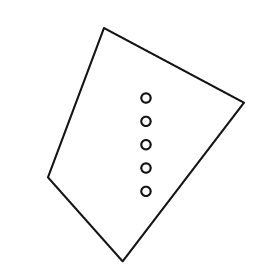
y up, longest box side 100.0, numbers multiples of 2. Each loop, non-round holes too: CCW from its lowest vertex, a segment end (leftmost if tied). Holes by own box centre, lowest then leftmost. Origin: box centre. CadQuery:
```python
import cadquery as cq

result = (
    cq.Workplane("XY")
    .moveTo(-10.0, -50.0)
    .lineTo(42.0, 18.0)
    .lineTo(-18.0, 50.0)
    .lineTo(-42.0, -14.0)
    .close()
    .moveTo(0.0, -20.0)
    .circle(2.0)
    .moveTo(0.0, -10.0)
    .circle(2.0)
    .moveTo(0.0, 0.0)
    .circle(2.0)
    .moveTo(0.0, 10.0)
    .circle(2.0)
    .moveTo(0.0, 20.0)
    .circle(2.0)
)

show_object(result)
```